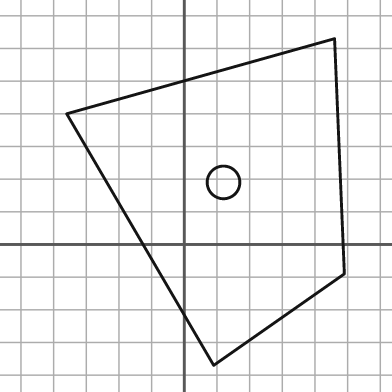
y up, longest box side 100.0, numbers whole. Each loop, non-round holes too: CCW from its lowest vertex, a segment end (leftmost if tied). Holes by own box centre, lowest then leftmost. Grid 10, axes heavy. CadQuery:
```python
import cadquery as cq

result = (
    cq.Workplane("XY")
    .moveTo(9.0, -37.0)
    .lineTo(49.0, -9.0)
    .lineTo(46.0, 63.0)
    .lineTo(-36.0, 40.0)
    .close()
    .moveTo(12.0, 19.0)
    .circle(5.0)
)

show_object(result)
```